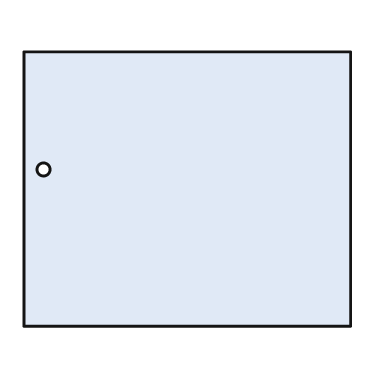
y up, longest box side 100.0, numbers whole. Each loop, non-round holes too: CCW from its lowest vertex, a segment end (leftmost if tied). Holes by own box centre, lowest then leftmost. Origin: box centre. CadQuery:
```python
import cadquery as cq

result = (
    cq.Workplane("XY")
    .moveTo(-50.0, -42.0)
    .lineTo(50.0, -42.0)
    .lineTo(50.0, 42.0)
    .lineTo(-50.0, 42.0)
    .close()
    .moveTo(-44.0, 6.0)
    .circle(2.0)
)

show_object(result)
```